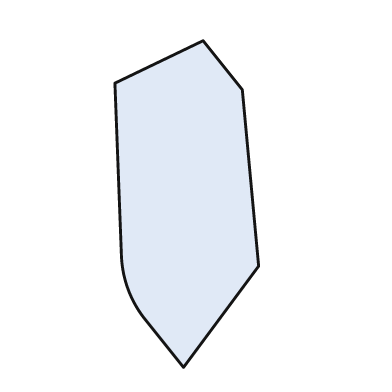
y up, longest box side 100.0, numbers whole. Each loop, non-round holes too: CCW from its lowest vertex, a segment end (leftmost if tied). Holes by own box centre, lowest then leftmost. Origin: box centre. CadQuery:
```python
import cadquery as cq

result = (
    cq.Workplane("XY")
    .moveTo(-1.0, -50.0)
    .lineTo(22.0, -19.0)
    .lineTo(17.0, 35.0)
    .lineTo(5.0, 50.0)
    .lineTo(-22.0, 37.0)
    .lineTo(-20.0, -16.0)
    .threePointArc((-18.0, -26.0), (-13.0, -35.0))
    .close()
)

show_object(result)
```